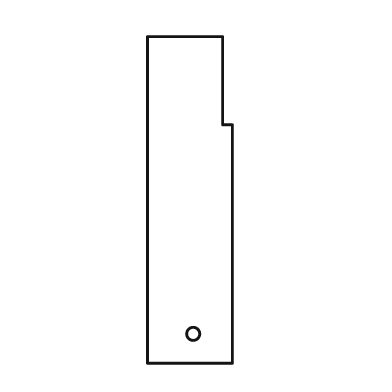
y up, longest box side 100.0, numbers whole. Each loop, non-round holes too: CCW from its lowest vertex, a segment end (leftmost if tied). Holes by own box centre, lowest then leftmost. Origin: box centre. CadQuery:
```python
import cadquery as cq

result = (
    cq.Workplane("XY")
    .moveTo(-13.0, -50.0)
    .lineTo(13.0, -50.0)
    .lineTo(13.0, 23.0)
    .lineTo(10.0, 23.0)
    .lineTo(10.0, 50.0)
    .lineTo(-13.0, 50.0)
    .close()
    .moveTo(1.0, -41.0)
    .circle(2.0)
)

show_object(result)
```